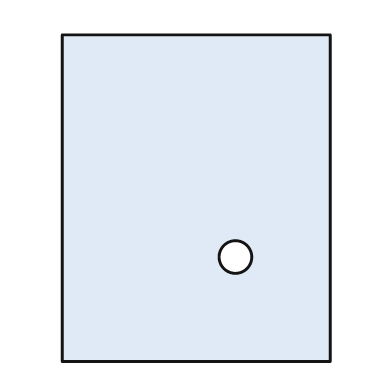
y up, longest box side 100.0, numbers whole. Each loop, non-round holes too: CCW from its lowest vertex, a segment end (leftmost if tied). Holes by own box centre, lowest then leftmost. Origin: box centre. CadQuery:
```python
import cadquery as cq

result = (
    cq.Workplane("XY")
    .moveTo(-41.0, -50.0)
    .lineTo(41.0, -50.0)
    .lineTo(41.0, 50.0)
    .lineTo(-41.0, 50.0)
    .close()
    .moveTo(12.0, -18.0)
    .circle(5.0)
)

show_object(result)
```